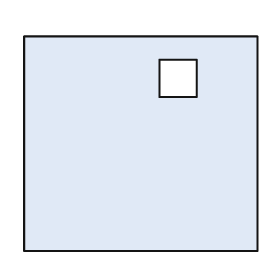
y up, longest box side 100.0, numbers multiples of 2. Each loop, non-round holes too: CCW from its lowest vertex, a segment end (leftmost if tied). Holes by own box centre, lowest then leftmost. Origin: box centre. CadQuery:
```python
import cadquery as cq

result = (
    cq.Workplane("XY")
    .moveTo(-50.0, -46.0)
    .lineTo(50.0, -46.0)
    .lineTo(50.0, 46.0)
    .lineTo(-50.0, 46.0)
    .close()
    .moveTo(8.0, 20.0)
    .lineTo(24.0, 20.0)
    .lineTo(24.0, 36.0)
    .lineTo(8.0, 36.0)
    .close()
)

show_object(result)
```